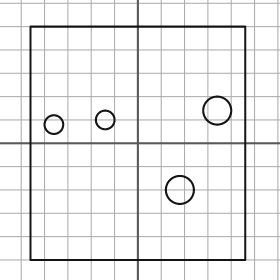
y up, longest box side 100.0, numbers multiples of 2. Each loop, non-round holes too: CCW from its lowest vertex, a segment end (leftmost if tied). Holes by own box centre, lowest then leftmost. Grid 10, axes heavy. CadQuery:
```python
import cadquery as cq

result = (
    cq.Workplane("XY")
    .moveTo(-46.0, -50.0)
    .lineTo(46.0, -50.0)
    .lineTo(46.0, 50.0)
    .lineTo(-46.0, 50.0)
    .close()
    .moveTo(18.0, -20.0)
    .circle(6.0)
    .moveTo(-36.0, 8.0)
    .circle(4.0)
    .moveTo(-14.0, 10.0)
    .circle(4.0)
    .moveTo(34.0, 14.0)
    .circle(6.0)
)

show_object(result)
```